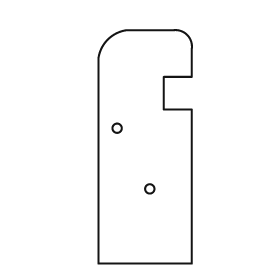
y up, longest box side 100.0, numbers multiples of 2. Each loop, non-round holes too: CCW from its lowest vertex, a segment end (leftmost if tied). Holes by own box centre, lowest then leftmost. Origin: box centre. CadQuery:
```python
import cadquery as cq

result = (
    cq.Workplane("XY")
    .moveTo(-20.0, -50.0)
    .lineTo(20.0, -50.0)
    .lineTo(20.0, 16.0)
    .lineTo(8.0, 16.0)
    .lineTo(8.0, 30.0)
    .lineTo(20.0, 30.0)
    .lineTo(20.0, 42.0)
    .threePointArc((18.0, 48.0), (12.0, 50.0))
    .lineTo(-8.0, 50.0)
    .threePointArc((-16.0, 46.0), (-20.0, 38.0))
    .close()
    .moveTo(2.0, -18.0)
    .circle(2.0)
    .moveTo(-12.0, 8.0)
    .circle(2.0)
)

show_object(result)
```